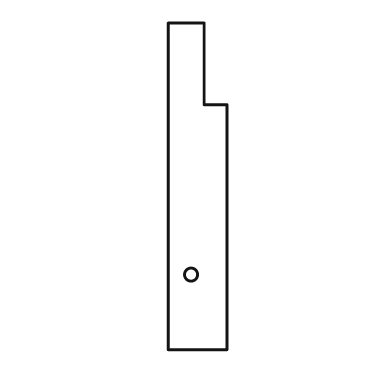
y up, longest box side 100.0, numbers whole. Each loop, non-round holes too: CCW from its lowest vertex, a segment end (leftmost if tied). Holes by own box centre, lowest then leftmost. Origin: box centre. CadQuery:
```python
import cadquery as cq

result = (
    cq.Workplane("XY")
    .moveTo(-9.0, -50.0)
    .lineTo(9.0, -50.0)
    .lineTo(9.0, 25.0)
    .lineTo(2.0, 25.0)
    .lineTo(2.0, 50.0)
    .lineTo(-9.0, 50.0)
    .close()
    .moveTo(-2.0, -27.0)
    .circle(2.0)
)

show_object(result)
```